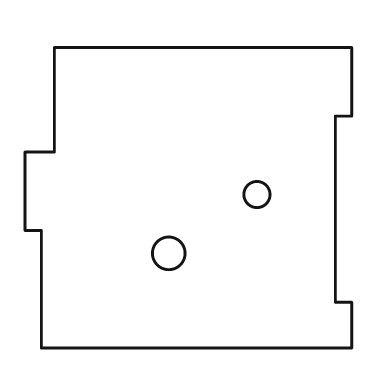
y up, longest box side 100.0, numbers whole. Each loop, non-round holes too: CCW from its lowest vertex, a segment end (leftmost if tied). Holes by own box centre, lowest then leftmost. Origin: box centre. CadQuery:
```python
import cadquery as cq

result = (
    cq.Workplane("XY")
    .moveTo(-45.0, -46.0)
    .lineTo(50.0, -46.0)
    .lineTo(50.0, -32.0)
    .lineTo(45.0, -32.0)
    .lineTo(45.0, 25.0)
    .lineTo(50.0, 25.0)
    .lineTo(50.0, 46.0)
    .lineTo(-41.0, 46.0)
    .lineTo(-41.0, 14.0)
    .lineTo(-50.0, 14.0)
    .lineTo(-50.0, -10.0)
    .lineTo(-45.0, -10.0)
    .close()
    .moveTo(-6.0, -17.0)
    .circle(5.0)
    .moveTo(21.0, 1.0)
    .circle(4.0)
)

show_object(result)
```